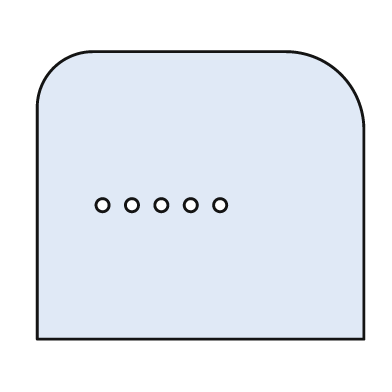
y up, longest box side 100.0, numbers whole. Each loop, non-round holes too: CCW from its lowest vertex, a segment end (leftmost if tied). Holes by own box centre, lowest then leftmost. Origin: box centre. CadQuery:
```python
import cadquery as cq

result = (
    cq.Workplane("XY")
    .moveTo(-50.0, -44.0)
    .lineTo(50.0, -44.0)
    .lineTo(50.0, 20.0)
    .threePointArc((43.0, 37.0), (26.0, 44.0))
    .lineTo(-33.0, 44.0)
    .threePointArc((-45.0, 39.0), (-50.0, 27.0))
    .close()
    .moveTo(-30.0, -3.0)
    .circle(2.0)
    .moveTo(-21.0, -3.0)
    .circle(2.0)
    .moveTo(-12.0, -3.0)
    .circle(2.0)
    .moveTo(-3.0, -3.0)
    .circle(2.0)
    .moveTo(6.0, -3.0)
    .circle(2.0)
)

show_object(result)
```